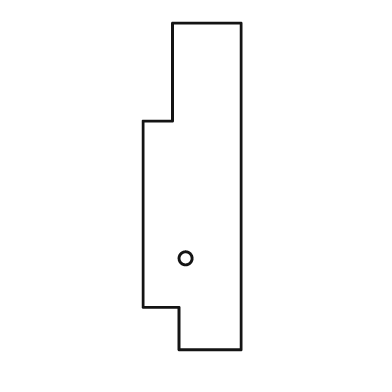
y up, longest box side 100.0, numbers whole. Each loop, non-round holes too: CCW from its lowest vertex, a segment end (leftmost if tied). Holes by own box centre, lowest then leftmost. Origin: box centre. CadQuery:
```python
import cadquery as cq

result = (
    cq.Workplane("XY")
    .moveTo(-4.0, -50.0)
    .lineTo(15.0, -50.0)
    .lineTo(15.0, 50.0)
    .lineTo(-6.0, 50.0)
    .lineTo(-6.0, 20.0)
    .lineTo(-15.0, 20.0)
    .lineTo(-15.0, -37.0)
    .lineTo(-4.0, -37.0)
    .close()
    .moveTo(-2.0, -22.0)
    .circle(2.0)
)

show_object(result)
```